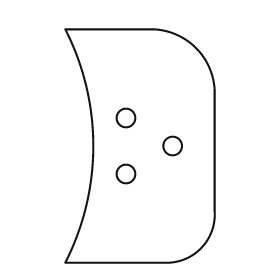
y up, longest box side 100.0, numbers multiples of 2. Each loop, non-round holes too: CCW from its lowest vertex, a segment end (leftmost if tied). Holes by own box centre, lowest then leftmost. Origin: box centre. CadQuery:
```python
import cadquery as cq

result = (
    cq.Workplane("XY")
    .moveTo(-32.0, -50.0)
    .lineTo(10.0, -50.0)
    .threePointArc((26.0, -44.0), (32.0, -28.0))
    .lineTo(32.0, 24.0)
    .threePointArc((24.0, 42.0), (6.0, 50.0))
    .lineTo(-32.0, 50.0)
    .threePointArc((-20.0, 0.0), (-32.0, -50.0))
    .close()
    .moveTo(-6.0, -12.0)
    .circle(4.0)
    .moveTo(14.0, 0.0)
    .circle(4.0)
    .moveTo(-6.0, 12.0)
    .circle(4.0)
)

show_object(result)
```